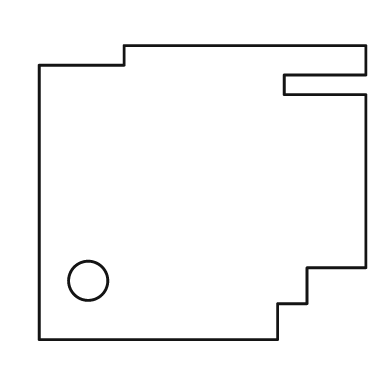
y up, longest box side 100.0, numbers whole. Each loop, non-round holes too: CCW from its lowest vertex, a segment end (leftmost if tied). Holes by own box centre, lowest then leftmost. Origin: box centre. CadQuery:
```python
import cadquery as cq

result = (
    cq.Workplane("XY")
    .moveTo(-50.0, -45.0)
    .lineTo(23.0, -45.0)
    .lineTo(23.0, -34.0)
    .lineTo(32.0, -34.0)
    .lineTo(32.0, -23.0)
    .lineTo(50.0, -23.0)
    .lineTo(50.0, 30.0)
    .lineTo(25.0, 30.0)
    .lineTo(25.0, 36.0)
    .lineTo(50.0, 36.0)
    .lineTo(50.0, 45.0)
    .lineTo(-24.0, 45.0)
    .lineTo(-24.0, 39.0)
    .lineTo(-50.0, 39.0)
    .close()
    .moveTo(-35.0, -27.0)
    .circle(6.0)
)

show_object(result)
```